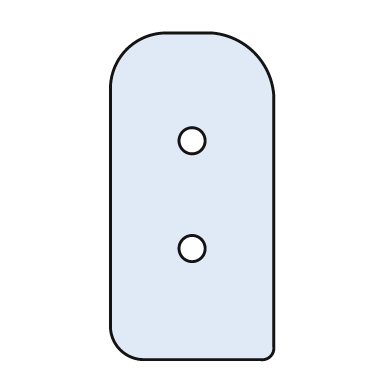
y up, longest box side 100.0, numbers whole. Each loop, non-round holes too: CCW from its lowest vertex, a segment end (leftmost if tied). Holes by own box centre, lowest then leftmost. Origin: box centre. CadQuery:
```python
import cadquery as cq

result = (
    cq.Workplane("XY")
    .moveTo(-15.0, -50.0)
    .lineTo(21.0, -50.0)
    .threePointArc((24.0, -49.0), (25.0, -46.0))
    .lineTo(25.0, 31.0)
    .threePointArc((19.0, 44.0), (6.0, 50.0))
    .lineTo(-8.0, 50.0)
    .threePointArc((-20.0, 45.0), (-25.0, 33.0))
    .lineTo(-25.0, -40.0)
    .threePointArc((-22.0, -47.0), (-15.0, -50.0))
    .close()
    .moveTo(0.0, -16.0)
    .circle(4.0)
    .moveTo(0.0, 17.0)
    .circle(4.0)
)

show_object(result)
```